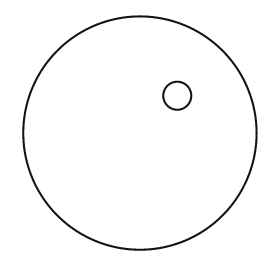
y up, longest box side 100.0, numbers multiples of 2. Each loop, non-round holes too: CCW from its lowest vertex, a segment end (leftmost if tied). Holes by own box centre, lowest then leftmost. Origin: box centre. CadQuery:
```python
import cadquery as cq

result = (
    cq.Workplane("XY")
    .moveTo(0.0, 0.0)
    .circle(50.0)
    .moveTo(16.0, 16.0)
    .circle(6.0)
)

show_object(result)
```